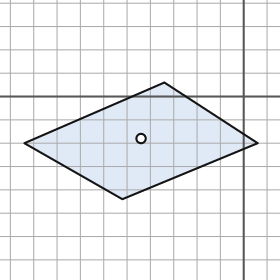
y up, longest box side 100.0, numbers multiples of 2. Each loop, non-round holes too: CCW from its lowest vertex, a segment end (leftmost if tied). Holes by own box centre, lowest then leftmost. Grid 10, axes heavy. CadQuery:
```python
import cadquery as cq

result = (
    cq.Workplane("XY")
    .moveTo(-52.0, -44.0)
    .lineTo(6.0, -20.0)
    .lineTo(-34.0, 6.0)
    .lineTo(-94.0, -20.0)
    .close()
    .moveTo(-44.0, -18.0)
    .circle(2.0)
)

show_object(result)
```